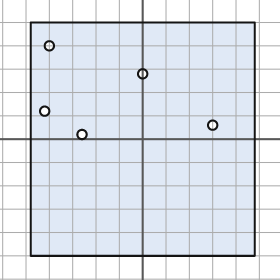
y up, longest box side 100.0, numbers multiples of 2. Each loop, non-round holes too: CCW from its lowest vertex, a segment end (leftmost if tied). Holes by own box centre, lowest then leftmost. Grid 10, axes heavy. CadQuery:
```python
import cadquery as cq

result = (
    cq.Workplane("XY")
    .moveTo(-48.0, -50.0)
    .lineTo(48.0, -50.0)
    .lineTo(48.0, 50.0)
    .lineTo(-48.0, 50.0)
    .close()
    .moveTo(-26.0, 2.0)
    .circle(2.0)
    .moveTo(30.0, 6.0)
    .circle(2.0)
    .moveTo(-42.0, 12.0)
    .circle(2.0)
    .moveTo(0.0, 28.0)
    .circle(2.0)
    .moveTo(-40.0, 40.0)
    .circle(2.0)
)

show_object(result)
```